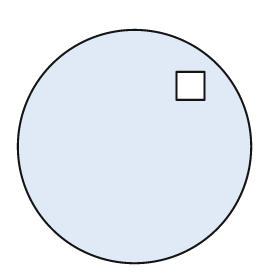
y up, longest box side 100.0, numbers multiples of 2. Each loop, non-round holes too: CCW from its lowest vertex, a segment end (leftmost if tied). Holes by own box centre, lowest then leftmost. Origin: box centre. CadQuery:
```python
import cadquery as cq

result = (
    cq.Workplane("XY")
    .moveTo(0.0, 0.0)
    .circle(50.0)
    .moveTo(18.0, 20.0)
    .lineTo(30.0, 20.0)
    .lineTo(30.0, 32.0)
    .lineTo(18.0, 32.0)
    .close()
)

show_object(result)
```